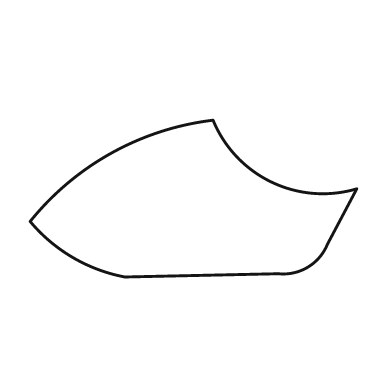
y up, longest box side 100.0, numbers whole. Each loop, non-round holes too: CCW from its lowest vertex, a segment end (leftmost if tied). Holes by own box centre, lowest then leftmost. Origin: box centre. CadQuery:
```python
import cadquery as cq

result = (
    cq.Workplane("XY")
    .moveTo(-21.0, -24.0)
    .lineTo(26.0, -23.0)
    .threePointArc((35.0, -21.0), (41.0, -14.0))
    .lineTo(50.0, 3.0)
    .threePointArc((24.0, 5.0), (6.0, 24.0))
    .threePointArc((-25.0, 14.0), (-50.0, -7.0))
    .threePointArc((-37.0, -18.0), (-21.0, -24.0))
    .close()
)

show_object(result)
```